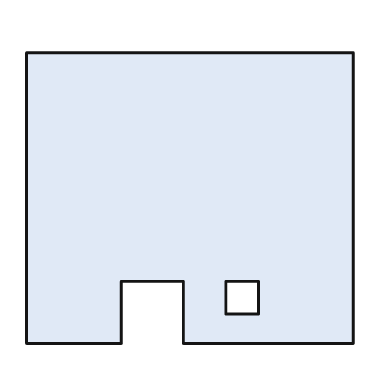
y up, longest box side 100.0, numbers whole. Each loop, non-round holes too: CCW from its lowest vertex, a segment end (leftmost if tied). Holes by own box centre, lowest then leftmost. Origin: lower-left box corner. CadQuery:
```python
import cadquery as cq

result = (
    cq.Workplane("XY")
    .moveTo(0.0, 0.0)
    .lineTo(29.0, 0.0)
    .lineTo(29.0, 19.0)
    .lineTo(48.0, 19.0)
    .lineTo(48.0, 0.0)
    .lineTo(100.0, 0.0)
    .lineTo(100.0, 89.0)
    .lineTo(0.0, 89.0)
    .close()
    .moveTo(61.0, 9.0)
    .lineTo(71.0, 9.0)
    .lineTo(71.0, 19.0)
    .lineTo(61.0, 19.0)
    .close()
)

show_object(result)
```